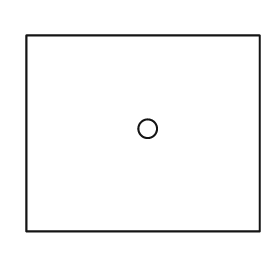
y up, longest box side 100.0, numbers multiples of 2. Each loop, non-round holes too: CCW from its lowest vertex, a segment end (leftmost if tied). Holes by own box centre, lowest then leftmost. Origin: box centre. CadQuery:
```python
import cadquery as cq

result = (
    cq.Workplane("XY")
    .moveTo(-50.0, -42.0)
    .lineTo(50.0, -42.0)
    .lineTo(50.0, 42.0)
    .lineTo(-50.0, 42.0)
    .close()
    .moveTo(2.0, 2.0)
    .circle(4.0)
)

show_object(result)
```